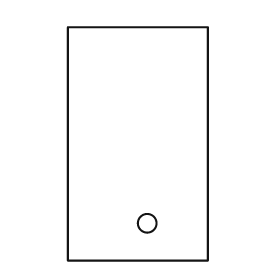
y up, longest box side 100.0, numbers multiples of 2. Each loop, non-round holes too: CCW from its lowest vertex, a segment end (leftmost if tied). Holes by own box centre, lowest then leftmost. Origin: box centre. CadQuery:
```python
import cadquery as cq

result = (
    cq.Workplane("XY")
    .moveTo(-30.0, -50.0)
    .lineTo(30.0, -50.0)
    .lineTo(30.0, 50.0)
    .lineTo(-30.0, 50.0)
    .close()
    .moveTo(4.0, -34.0)
    .circle(4.0)
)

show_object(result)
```